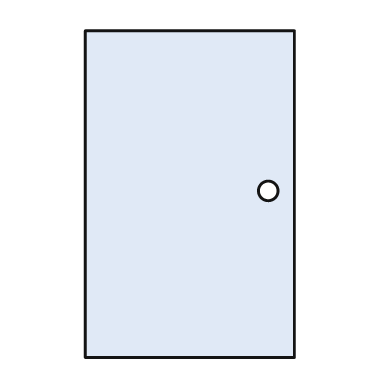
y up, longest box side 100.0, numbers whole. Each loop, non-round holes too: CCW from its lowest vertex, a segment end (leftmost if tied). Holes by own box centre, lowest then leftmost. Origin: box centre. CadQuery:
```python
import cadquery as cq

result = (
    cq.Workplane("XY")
    .moveTo(-32.0, -50.0)
    .lineTo(32.0, -50.0)
    .lineTo(32.0, 50.0)
    .lineTo(-32.0, 50.0)
    .close()
    .moveTo(24.0, 1.0)
    .circle(3.0)
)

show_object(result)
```